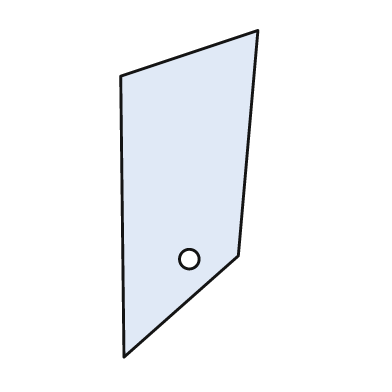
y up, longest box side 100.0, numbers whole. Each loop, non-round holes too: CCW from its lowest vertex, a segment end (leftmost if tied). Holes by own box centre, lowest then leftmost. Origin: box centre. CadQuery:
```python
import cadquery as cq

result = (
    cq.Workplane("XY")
    .moveTo(-20.0, -50.0)
    .lineTo(15.0, -19.0)
    .lineTo(21.0, 50.0)
    .lineTo(-21.0, 36.0)
    .close()
    .moveTo(0.0, -20.0)
    .circle(3.0)
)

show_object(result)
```